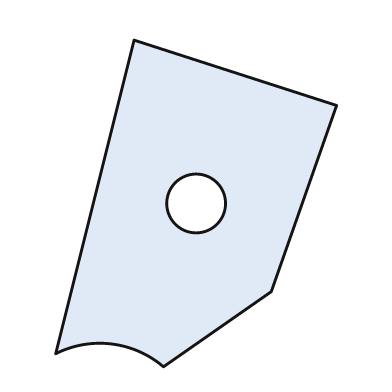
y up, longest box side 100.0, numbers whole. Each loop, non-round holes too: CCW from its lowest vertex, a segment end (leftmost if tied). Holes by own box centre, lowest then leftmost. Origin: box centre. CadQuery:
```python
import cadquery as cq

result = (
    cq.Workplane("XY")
    .moveTo(-10.0, -50.0)
    .lineTo(23.0, -27.0)
    .lineTo(43.0, 30.0)
    .lineTo(-19.0, 50.0)
    .lineTo(-43.0, -46.0)
    .threePointArc((-26.0, -43.0), (-10.0, -50.0))
    .close()
    .moveTo(0.0, 0.0)
    .circle(9.0)
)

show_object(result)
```